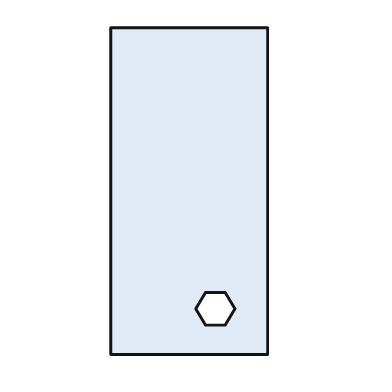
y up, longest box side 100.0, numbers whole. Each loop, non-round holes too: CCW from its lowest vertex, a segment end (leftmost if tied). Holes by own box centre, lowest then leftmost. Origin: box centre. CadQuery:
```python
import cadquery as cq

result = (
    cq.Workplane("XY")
    .moveTo(-24.0, -50.0)
    .lineTo(24.0, -50.0)
    .lineTo(24.0, 50.0)
    .lineTo(-24.0, 50.0)
    .close()
    .moveTo(5.0, -41.0)
    .lineTo(11.0, -41.0)
    .lineTo(14.0, -36.0)
    .lineTo(11.0, -31.0)
    .lineTo(5.0, -31.0)
    .lineTo(2.0, -36.0)
    .close()
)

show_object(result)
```